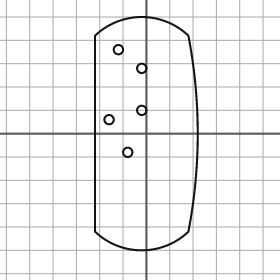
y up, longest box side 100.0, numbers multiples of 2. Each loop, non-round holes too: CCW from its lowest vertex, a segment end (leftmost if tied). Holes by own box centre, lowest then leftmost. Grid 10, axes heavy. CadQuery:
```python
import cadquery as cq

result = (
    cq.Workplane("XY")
    .moveTo(-22.0, -42.0)
    .threePointArc((-2.0, -50.0), (18.0, -42.0))
    .threePointArc((22.0, 0.0), (18.0, 42.0))
    .threePointArc((-2.0, 50.0), (-22.0, 42.0))
    .close()
    .moveTo(-8.0, -8.0)
    .circle(2.0)
    .moveTo(-16.0, 6.0)
    .circle(2.0)
    .moveTo(-2.0, 10.0)
    .circle(2.0)
    .moveTo(-2.0, 28.0)
    .circle(2.0)
    .moveTo(-12.0, 36.0)
    .circle(2.0)
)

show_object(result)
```